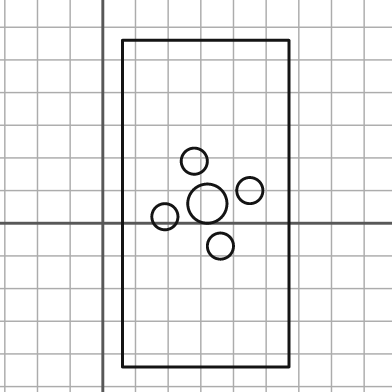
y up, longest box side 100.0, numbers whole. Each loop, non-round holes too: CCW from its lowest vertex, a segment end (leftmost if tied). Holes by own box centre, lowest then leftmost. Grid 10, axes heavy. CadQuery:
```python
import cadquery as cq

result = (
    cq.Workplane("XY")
    .moveTo(6.0, -44.0)
    .lineTo(57.0, -44.0)
    .lineTo(57.0, 56.0)
    .lineTo(6.0, 56.0)
    .close()
    .moveTo(36.0, -7.0)
    .circle(4.0)
    .moveTo(19.0, 2.0)
    .circle(4.0)
    .moveTo(32.0, 6.0)
    .circle(6.0)
    .moveTo(45.0, 10.0)
    .circle(4.0)
    .moveTo(28.0, 19.0)
    .circle(4.0)
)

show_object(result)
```